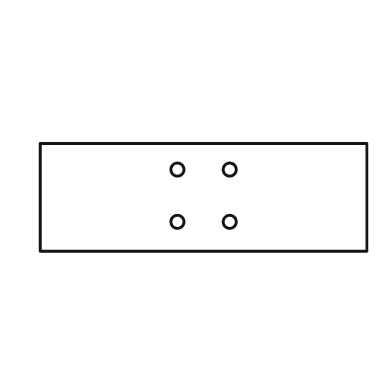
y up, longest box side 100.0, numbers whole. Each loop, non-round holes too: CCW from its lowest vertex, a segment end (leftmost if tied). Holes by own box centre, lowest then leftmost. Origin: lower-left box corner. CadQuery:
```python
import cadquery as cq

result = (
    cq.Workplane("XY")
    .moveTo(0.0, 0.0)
    .lineTo(100.0, 0.0)
    .lineTo(100.0, 33.0)
    .lineTo(0.0, 33.0)
    .close()
    .moveTo(42.0, 9.0)
    .circle(2.0)
    .moveTo(58.0, 9.0)
    .circle(2.0)
    .moveTo(42.0, 25.0)
    .circle(2.0)
    .moveTo(58.0, 25.0)
    .circle(2.0)
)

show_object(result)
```